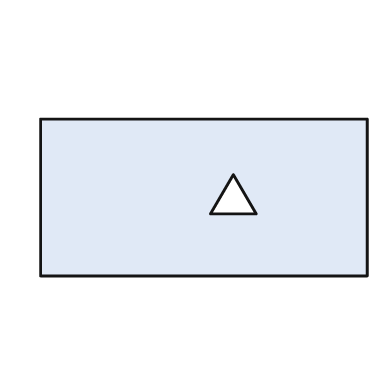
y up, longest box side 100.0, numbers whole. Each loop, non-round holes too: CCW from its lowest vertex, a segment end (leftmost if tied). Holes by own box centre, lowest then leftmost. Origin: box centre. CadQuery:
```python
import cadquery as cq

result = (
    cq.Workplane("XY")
    .moveTo(-50.0, -24.0)
    .lineTo(50.0, -24.0)
    .lineTo(50.0, 24.0)
    .lineTo(-50.0, 24.0)
    .close()
    .moveTo(2.0, -5.0)
    .lineTo(16.0, -5.0)
    .lineTo(9.0, 7.0)
    .close()
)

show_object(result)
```